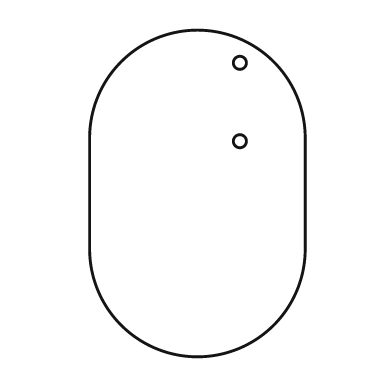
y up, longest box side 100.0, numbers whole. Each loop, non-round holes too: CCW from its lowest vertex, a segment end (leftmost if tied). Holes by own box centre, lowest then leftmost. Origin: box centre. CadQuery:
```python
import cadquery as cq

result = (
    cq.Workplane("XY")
    .moveTo(-33.0, -17.0)
    .threePointArc((0.0, -50.0), (33.0, -17.0))
    .lineTo(33.0, 17.0)
    .threePointArc((0.0, 50.0), (-33.0, 17.0))
    .close()
    .moveTo(13.0, 16.0)
    .circle(2.0)
    .moveTo(13.0, 40.0)
    .circle(2.0)
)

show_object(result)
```